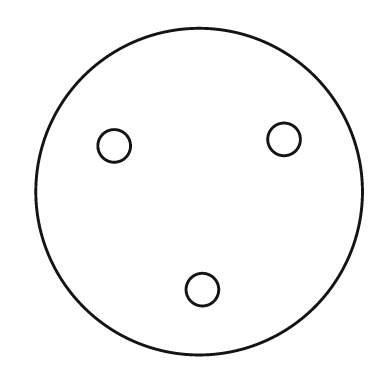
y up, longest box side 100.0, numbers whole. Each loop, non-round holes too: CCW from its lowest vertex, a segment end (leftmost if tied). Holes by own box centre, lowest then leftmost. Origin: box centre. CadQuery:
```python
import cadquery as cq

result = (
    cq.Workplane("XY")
    .moveTo(0.0, 0.0)
    .circle(50.0)
    .moveTo(1.0, -30.0)
    .circle(5.0)
    .moveTo(-26.0, 14.0)
    .circle(5.0)
    .moveTo(26.0, 16.0)
    .circle(5.0)
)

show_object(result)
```